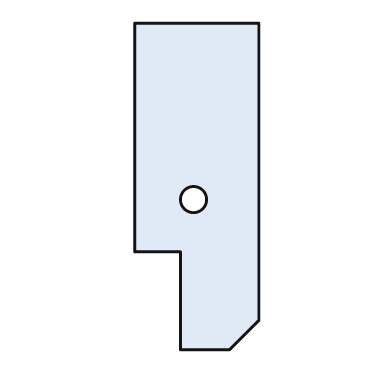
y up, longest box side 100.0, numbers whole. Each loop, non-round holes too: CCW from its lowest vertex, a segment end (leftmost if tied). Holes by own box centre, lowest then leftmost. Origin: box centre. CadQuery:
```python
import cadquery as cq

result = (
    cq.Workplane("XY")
    .moveTo(-5.0, -50.0)
    .lineTo(10.0, -50.0)
    .lineTo(19.0, -41.0)
    .lineTo(19.0, 50.0)
    .lineTo(-19.0, 50.0)
    .lineTo(-19.0, -20.0)
    .lineTo(-5.0, -20.0)
    .close()
    .moveTo(-1.0, -4.0)
    .circle(4.0)
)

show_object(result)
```